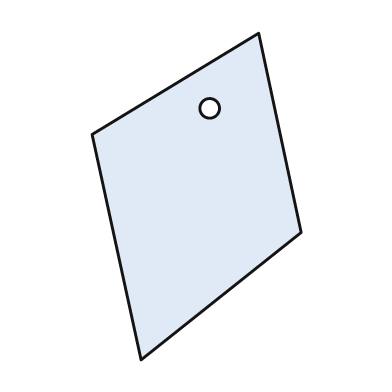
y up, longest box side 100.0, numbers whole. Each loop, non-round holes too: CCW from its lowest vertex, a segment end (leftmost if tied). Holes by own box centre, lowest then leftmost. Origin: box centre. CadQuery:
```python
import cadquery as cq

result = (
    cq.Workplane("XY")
    .moveTo(-17.0, -50.0)
    .lineTo(32.0, -11.0)
    .lineTo(19.0, 50.0)
    .lineTo(-32.0, 19.0)
    .close()
    .moveTo(4.0, 27.0)
    .circle(3.0)
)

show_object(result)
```